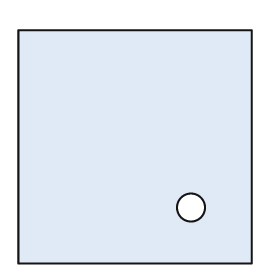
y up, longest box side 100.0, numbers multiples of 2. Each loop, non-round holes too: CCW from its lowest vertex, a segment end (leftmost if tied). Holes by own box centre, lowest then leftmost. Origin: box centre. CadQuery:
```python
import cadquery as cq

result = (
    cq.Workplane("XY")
    .moveTo(-50.0, -50.0)
    .lineTo(50.0, -50.0)
    .lineTo(50.0, 50.0)
    .lineTo(-50.0, 50.0)
    .close()
    .moveTo(24.0, -26.0)
    .circle(6.0)
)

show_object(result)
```